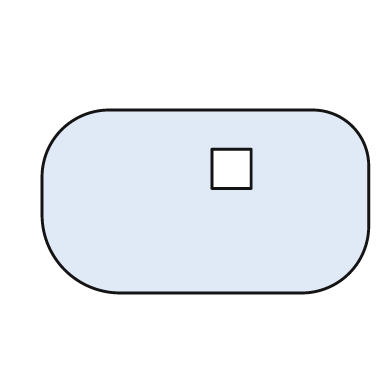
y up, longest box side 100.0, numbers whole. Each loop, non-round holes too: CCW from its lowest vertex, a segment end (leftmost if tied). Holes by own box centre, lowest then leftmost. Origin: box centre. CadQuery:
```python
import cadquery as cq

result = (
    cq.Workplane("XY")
    .moveTo(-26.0, -28.0)
    .lineTo(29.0, -28.0)
    .threePointArc((44.0, -22.0), (50.0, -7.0))
    .lineTo(50.0, 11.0)
    .threePointArc((45.0, 23.0), (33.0, 28.0))
    .lineTo(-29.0, 28.0)
    .threePointArc((-44.0, 22.0), (-50.0, 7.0))
    .lineTo(-50.0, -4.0)
    .threePointArc((-43.0, -21.0), (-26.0, -28.0))
    .close()
    .moveTo(2.0, 4.0)
    .lineTo(14.0, 4.0)
    .lineTo(14.0, 16.0)
    .lineTo(2.0, 16.0)
    .close()
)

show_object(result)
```